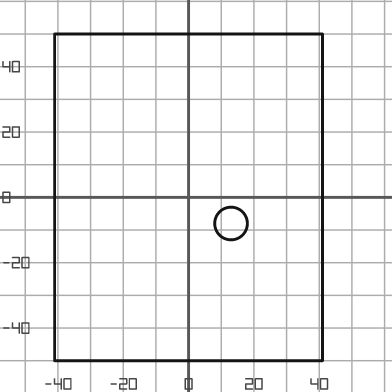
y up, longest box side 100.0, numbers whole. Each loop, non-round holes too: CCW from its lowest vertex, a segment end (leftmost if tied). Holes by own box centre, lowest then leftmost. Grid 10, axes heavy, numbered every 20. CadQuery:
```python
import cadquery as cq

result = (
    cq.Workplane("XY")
    .moveTo(-41.0, -50.0)
    .lineTo(41.0, -50.0)
    .lineTo(41.0, 50.0)
    .lineTo(-41.0, 50.0)
    .close()
    .moveTo(13.0, -8.0)
    .circle(5.0)
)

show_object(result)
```